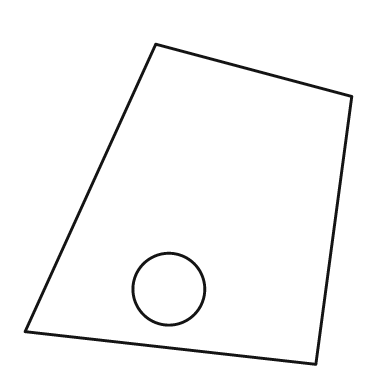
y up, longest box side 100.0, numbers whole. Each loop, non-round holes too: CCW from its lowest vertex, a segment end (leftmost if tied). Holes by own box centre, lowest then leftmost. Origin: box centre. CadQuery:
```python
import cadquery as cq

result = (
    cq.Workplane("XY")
    .moveTo(39.0, -49.0)
    .lineTo(50.0, 33.0)
    .lineTo(-10.0, 49.0)
    .lineTo(-50.0, -39.0)
    .close()
    .moveTo(-6.0, -26.0)
    .circle(11.0)
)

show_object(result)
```